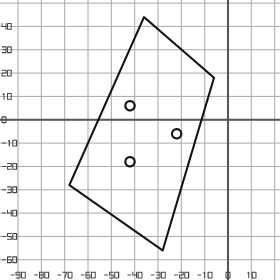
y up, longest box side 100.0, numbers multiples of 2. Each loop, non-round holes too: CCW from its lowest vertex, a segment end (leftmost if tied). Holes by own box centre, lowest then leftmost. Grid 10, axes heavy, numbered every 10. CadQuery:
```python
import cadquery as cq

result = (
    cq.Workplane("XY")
    .moveTo(-28.0, -56.0)
    .lineTo(-6.0, 18.0)
    .lineTo(-36.0, 44.0)
    .lineTo(-68.0, -28.0)
    .close()
    .moveTo(-42.0, -18.0)
    .circle(2.0)
    .moveTo(-22.0, -6.0)
    .circle(2.0)
    .moveTo(-42.0, 6.0)
    .circle(2.0)
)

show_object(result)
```